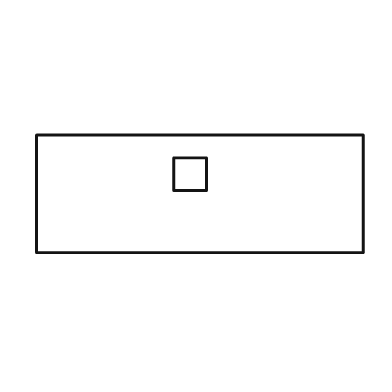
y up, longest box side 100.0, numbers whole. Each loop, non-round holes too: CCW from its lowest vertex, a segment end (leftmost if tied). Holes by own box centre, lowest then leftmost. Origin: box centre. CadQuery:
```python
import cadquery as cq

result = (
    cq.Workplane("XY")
    .moveTo(-50.0, -18.0)
    .lineTo(50.0, -18.0)
    .lineTo(50.0, 18.0)
    .lineTo(-50.0, 18.0)
    .close()
    .moveTo(-8.0, 1.0)
    .lineTo(2.0, 1.0)
    .lineTo(2.0, 11.0)
    .lineTo(-8.0, 11.0)
    .close()
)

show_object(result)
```